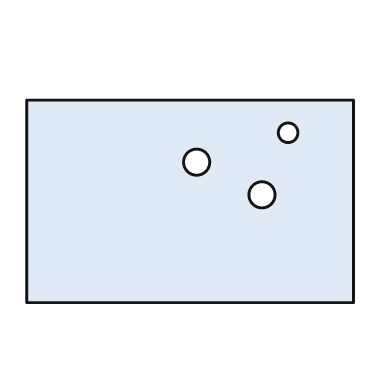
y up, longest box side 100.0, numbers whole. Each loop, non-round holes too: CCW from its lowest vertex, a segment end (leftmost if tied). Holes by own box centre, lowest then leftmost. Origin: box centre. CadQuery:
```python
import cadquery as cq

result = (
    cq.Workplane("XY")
    .moveTo(-50.0, -31.0)
    .lineTo(50.0, -31.0)
    .lineTo(50.0, 31.0)
    .lineTo(-50.0, 31.0)
    .close()
    .moveTo(22.0, 2.0)
    .circle(4.0)
    .moveTo(2.0, 12.0)
    .circle(4.0)
    .moveTo(30.0, 21.0)
    .circle(3.0)
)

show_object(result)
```